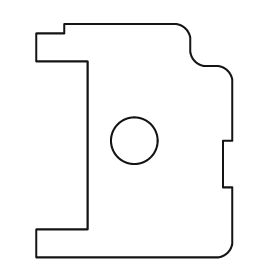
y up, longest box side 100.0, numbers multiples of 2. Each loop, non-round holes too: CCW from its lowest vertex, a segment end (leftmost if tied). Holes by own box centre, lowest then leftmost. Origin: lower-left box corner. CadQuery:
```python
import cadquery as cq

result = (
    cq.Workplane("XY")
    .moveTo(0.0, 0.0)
    .lineTo(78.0, 0.0)
    .threePointArc((82.0, 2.0), (84.0, 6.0))
    .lineTo(84.0, 30.0)
    .lineTo(80.0, 30.0)
    .lineTo(80.0, 50.0)
    .lineTo(84.0, 50.0)
    .lineTo(84.0, 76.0)
    .threePointArc((82.0, 80.0), (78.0, 82.0))
    .lineTo(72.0, 82.0)
    .threePointArc((68.0, 84.0), (66.0, 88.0))
    .lineTo(66.0, 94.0)
    .threePointArc((64.0, 98.0), (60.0, 100.0))
    .lineTo(12.0, 100.0)
    .lineTo(12.0, 96.0)
    .lineTo(0.0, 96.0)
    .lineTo(0.0, 84.0)
    .lineTo(22.0, 84.0)
    .lineTo(22.0, 12.0)
    .lineTo(0.0, 12.0)
    .close()
    .moveTo(42.0, 50.0)
    .circle(10.0)
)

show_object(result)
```